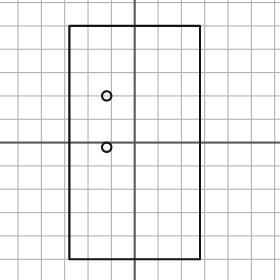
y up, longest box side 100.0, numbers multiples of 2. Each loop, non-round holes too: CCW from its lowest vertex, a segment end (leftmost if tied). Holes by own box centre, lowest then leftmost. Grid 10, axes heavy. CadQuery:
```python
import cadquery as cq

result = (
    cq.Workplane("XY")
    .moveTo(-28.0, -50.0)
    .lineTo(28.0, -50.0)
    .lineTo(28.0, 50.0)
    .lineTo(-28.0, 50.0)
    .close()
    .moveTo(-12.0, -2.0)
    .circle(2.0)
    .moveTo(-12.0, 20.0)
    .circle(2.0)
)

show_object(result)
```